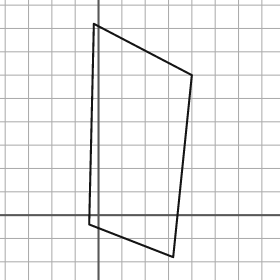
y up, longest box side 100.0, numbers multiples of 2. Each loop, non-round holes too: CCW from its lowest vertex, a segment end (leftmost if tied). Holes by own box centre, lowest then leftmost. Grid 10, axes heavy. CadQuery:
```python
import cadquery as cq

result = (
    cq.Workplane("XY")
    .moveTo(32.0, -18.0)
    .lineTo(40.0, 60.0)
    .lineTo(-2.0, 82.0)
    .lineTo(-4.0, -4.0)
    .close()
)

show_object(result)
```